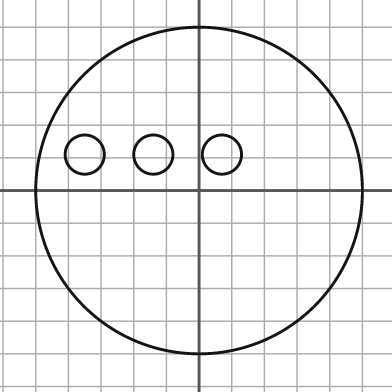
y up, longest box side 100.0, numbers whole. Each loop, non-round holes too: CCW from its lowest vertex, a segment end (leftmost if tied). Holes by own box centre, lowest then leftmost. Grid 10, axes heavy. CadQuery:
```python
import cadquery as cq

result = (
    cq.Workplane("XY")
    .moveTo(0.0, 0.0)
    .circle(50.0)
    .moveTo(-35.0, 11.0)
    .circle(6.0)
    .moveTo(-14.0, 11.0)
    .circle(6.0)
    .moveTo(7.0, 11.0)
    .circle(6.0)
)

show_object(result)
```